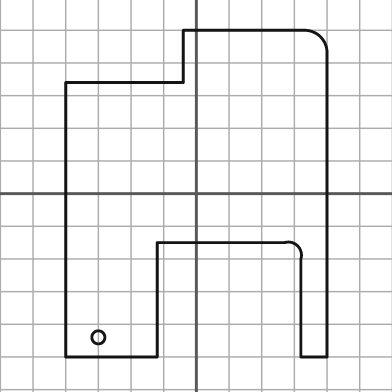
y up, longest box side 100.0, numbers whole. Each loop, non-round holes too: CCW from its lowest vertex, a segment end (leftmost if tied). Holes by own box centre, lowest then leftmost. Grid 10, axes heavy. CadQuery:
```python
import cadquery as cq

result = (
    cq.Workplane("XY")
    .moveTo(-40.0, -50.0)
    .lineTo(-12.0, -50.0)
    .lineTo(-12.0, -15.0)
    .lineTo(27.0, -15.0)
    .threePointArc((31.0, -16.0), (32.0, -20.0))
    .lineTo(32.0, -50.0)
    .lineTo(40.0, -50.0)
    .lineTo(40.0, 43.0)
    .threePointArc((38.0, 48.0), (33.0, 50.0))
    .lineTo(-4.0, 50.0)
    .lineTo(-4.0, 34.0)
    .lineTo(-40.0, 34.0)
    .close()
    .moveTo(-30.0, -44.0)
    .circle(2.0)
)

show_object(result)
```